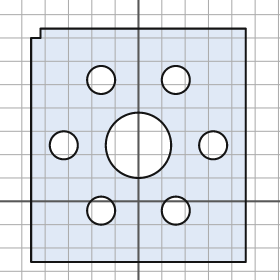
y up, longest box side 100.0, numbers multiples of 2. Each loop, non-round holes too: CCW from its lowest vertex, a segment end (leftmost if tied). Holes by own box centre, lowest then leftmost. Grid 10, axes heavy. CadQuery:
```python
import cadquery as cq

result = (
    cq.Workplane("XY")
    .moveTo(-46.0, -26.0)
    .lineTo(46.0, -26.0)
    .lineTo(46.0, 74.0)
    .lineTo(-42.0, 74.0)
    .lineTo(-42.0, 70.0)
    .lineTo(-46.0, 70.0)
    .close()
    .moveTo(-16.0, -4.0)
    .circle(6.0)
    .moveTo(16.0, -4.0)
    .circle(6.0)
    .moveTo(-32.0, 24.0)
    .circle(6.0)
    .moveTo(0.0, 24.0)
    .circle(14.0)
    .moveTo(32.0, 24.0)
    .circle(6.0)
    .moveTo(-16.0, 52.0)
    .circle(6.0)
    .moveTo(16.0, 52.0)
    .circle(6.0)
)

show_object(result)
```